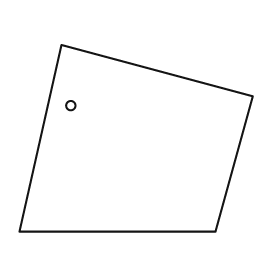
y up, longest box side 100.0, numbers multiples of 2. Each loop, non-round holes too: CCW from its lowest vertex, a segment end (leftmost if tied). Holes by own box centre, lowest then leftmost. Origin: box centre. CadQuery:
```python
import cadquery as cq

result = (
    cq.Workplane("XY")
    .moveTo(-50.0, -40.0)
    .lineTo(34.0, -40.0)
    .lineTo(50.0, 18.0)
    .lineTo(-32.0, 40.0)
    .close()
    .moveTo(-28.0, 14.0)
    .circle(2.0)
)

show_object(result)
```